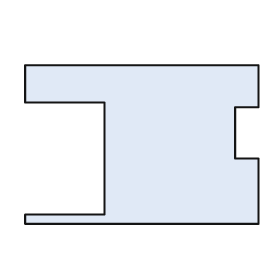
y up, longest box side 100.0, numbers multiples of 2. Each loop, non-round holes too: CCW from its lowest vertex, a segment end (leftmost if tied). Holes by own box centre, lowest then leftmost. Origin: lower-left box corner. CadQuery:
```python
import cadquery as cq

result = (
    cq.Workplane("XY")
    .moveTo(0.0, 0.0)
    .lineTo(100.0, 0.0)
    .lineTo(100.0, 28.0)
    .lineTo(90.0, 28.0)
    .lineTo(90.0, 50.0)
    .lineTo(100.0, 50.0)
    .lineTo(100.0, 68.0)
    .lineTo(0.0, 68.0)
    .lineTo(0.0, 52.0)
    .lineTo(34.0, 52.0)
    .lineTo(34.0, 4.0)
    .lineTo(0.0, 4.0)
    .close()
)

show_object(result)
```